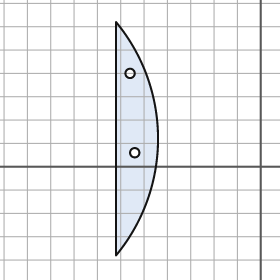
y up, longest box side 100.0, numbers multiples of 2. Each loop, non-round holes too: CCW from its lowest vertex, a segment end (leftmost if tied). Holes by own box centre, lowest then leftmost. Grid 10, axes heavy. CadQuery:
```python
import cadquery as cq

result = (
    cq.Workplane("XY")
    .moveTo(-62.0, -38.0)
    .threePointArc((-44.0, 12.0), (-62.0, 62.0))
    .close()
    .moveTo(-54.0, 6.0)
    .circle(2.0)
    .moveTo(-56.0, 40.0)
    .circle(2.0)
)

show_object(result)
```